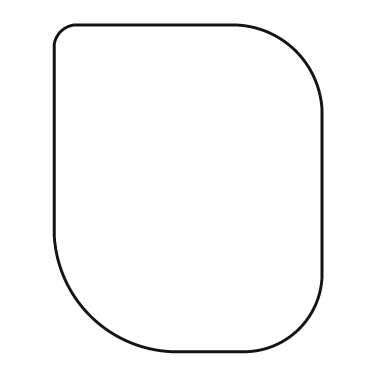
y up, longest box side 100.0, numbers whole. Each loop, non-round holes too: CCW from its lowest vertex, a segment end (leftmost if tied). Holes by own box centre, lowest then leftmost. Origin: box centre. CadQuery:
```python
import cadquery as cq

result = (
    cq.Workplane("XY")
    .moveTo(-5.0, -50.0)
    .lineTo(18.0, -50.0)
    .threePointArc((34.0, -43.0), (41.0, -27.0))
    .lineTo(41.0, 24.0)
    .threePointArc((33.0, 42.0), (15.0, 50.0))
    .lineTo(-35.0, 50.0)
    .threePointArc((-39.0, 48.0), (-41.0, 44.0))
    .lineTo(-41.0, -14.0)
    .threePointArc((-30.0, -39.0), (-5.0, -50.0))
    .close()
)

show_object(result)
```